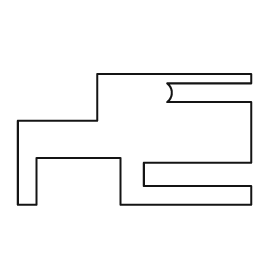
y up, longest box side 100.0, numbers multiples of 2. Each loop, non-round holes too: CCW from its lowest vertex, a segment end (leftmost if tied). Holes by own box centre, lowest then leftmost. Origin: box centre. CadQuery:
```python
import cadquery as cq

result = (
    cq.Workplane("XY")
    .moveTo(-50.0, -28.0)
    .lineTo(-42.0, -28.0)
    .lineTo(-42.0, -8.0)
    .lineTo(-6.0, -8.0)
    .lineTo(-6.0, -28.0)
    .lineTo(50.0, -28.0)
    .lineTo(50.0, -20.0)
    .lineTo(4.0, -20.0)
    .lineTo(4.0, -10.0)
    .lineTo(50.0, -10.0)
    .lineTo(50.0, 16.0)
    .lineTo(14.0, 16.0)
    .threePointArc((16.0, 20.0), (14.0, 24.0))
    .lineTo(50.0, 24.0)
    .lineTo(50.0, 28.0)
    .lineTo(-16.0, 28.0)
    .lineTo(-16.0, 8.0)
    .lineTo(-50.0, 8.0)
    .close()
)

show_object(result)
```